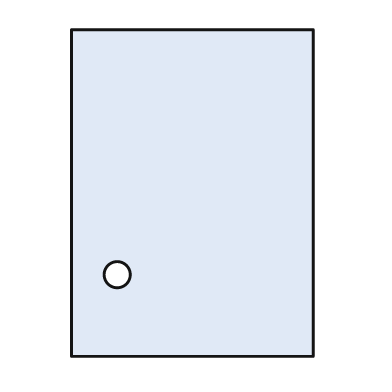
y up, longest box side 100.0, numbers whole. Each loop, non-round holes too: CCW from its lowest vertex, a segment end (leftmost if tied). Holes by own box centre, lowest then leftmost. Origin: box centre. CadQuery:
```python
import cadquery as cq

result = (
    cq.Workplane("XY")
    .moveTo(-37.0, -50.0)
    .lineTo(37.0, -50.0)
    .lineTo(37.0, 50.0)
    .lineTo(-37.0, 50.0)
    .close()
    .moveTo(-23.0, -25.0)
    .circle(4.0)
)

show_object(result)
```